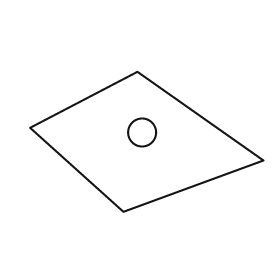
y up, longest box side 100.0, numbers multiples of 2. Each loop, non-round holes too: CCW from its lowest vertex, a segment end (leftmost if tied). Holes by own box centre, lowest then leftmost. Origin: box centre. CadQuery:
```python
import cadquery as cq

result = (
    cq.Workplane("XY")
    .moveTo(-10.0, -30.0)
    .lineTo(50.0, -8.0)
    .lineTo(-4.0, 30.0)
    .lineTo(-50.0, 6.0)
    .close()
    .moveTo(-2.0, 4.0)
    .circle(6.0)
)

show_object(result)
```